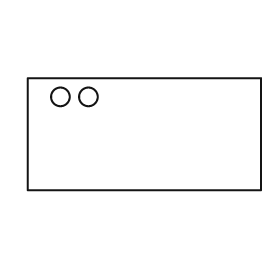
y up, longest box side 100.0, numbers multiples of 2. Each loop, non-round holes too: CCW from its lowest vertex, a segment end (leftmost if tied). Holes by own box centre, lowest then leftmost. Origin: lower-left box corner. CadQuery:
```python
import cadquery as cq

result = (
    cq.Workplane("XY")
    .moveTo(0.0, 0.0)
    .lineTo(100.0, 0.0)
    .lineTo(100.0, 48.0)
    .lineTo(0.0, 48.0)
    .close()
    .moveTo(14.0, 40.0)
    .circle(4.0)
    .moveTo(26.0, 40.0)
    .circle(4.0)
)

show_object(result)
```